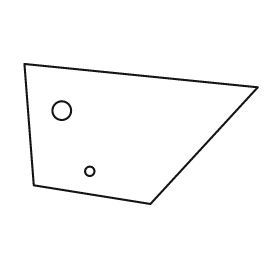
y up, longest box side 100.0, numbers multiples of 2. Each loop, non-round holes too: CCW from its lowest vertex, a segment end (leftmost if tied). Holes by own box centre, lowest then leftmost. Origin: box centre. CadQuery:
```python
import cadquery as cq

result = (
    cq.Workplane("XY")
    .moveTo(4.0, -30.0)
    .lineTo(50.0, 20.0)
    .lineTo(-50.0, 30.0)
    .lineTo(-46.0, -22.0)
    .close()
    .moveTo(-22.0, -16.0)
    .circle(2.0)
    .moveTo(-34.0, 10.0)
    .circle(4.0)
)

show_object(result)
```